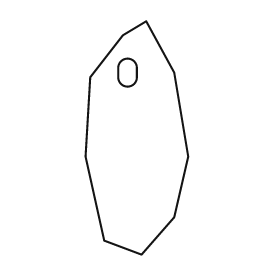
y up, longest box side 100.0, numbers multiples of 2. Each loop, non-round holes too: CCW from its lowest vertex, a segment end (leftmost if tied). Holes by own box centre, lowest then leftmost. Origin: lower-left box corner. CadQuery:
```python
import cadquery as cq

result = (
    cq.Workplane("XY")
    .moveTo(24.0, 0.0)
    .lineTo(38.0, 16.0)
    .lineTo(44.0, 42.0)
    .lineTo(38.0, 78.0)
    .lineTo(26.0, 100.0)
    .lineTo(16.0, 94.0)
    .lineTo(2.0, 76.0)
    .lineTo(0.0, 42.0)
    .lineTo(8.0, 6.0)
    .close()
    .moveTo(14.0, 76.0)
    .threePointArc((18.0, 72.0), (22.0, 76.0))
    .lineTo(22.0, 80.0)
    .threePointArc((18.0, 84.0), (14.0, 80.0))
    .close()
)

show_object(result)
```